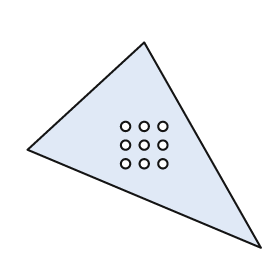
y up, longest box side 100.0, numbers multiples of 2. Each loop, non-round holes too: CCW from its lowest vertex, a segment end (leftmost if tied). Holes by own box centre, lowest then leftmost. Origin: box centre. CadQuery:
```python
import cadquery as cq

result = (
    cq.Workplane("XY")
    .moveTo(50.0, -44.0)
    .lineTo(0.0, 44.0)
    .lineTo(-50.0, -2.0)
    .close()
    .moveTo(-8.0, -8.0)
    .circle(2.0)
    .moveTo(0.0, -8.0)
    .circle(2.0)
    .moveTo(8.0, -8.0)
    .circle(2.0)
    .moveTo(-8.0, 0.0)
    .circle(2.0)
    .moveTo(0.0, 0.0)
    .circle(2.0)
    .moveTo(8.0, 0.0)
    .circle(2.0)
    .moveTo(-8.0, 8.0)
    .circle(2.0)
    .moveTo(0.0, 8.0)
    .circle(2.0)
    .moveTo(8.0, 8.0)
    .circle(2.0)
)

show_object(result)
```